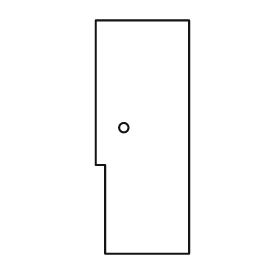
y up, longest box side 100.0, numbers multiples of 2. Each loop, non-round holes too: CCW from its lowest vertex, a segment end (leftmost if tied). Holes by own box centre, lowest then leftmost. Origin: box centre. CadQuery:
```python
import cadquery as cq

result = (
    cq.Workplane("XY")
    .moveTo(-16.0, -50.0)
    .lineTo(20.0, -50.0)
    .lineTo(20.0, 50.0)
    .lineTo(-20.0, 50.0)
    .lineTo(-20.0, -12.0)
    .lineTo(-16.0, -12.0)
    .close()
    .moveTo(-8.0, 4.0)
    .circle(2.0)
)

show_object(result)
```